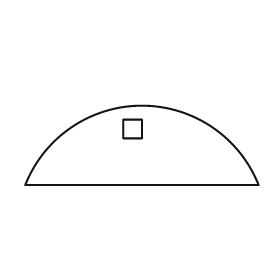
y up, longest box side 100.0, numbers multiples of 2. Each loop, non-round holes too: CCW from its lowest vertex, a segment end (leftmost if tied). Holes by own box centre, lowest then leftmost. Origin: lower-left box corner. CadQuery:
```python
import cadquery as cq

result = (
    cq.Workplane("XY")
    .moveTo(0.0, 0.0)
    .lineTo(100.0, 0.0)
    .threePointArc((50.0, 34.0), (0.0, 0.0))
    .close()
    .moveTo(42.0, 20.0)
    .lineTo(50.0, 20.0)
    .lineTo(50.0, 28.0)
    .lineTo(42.0, 28.0)
    .close()
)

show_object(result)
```